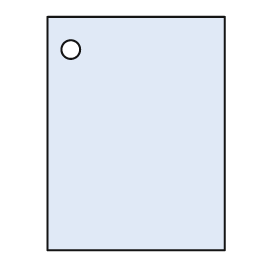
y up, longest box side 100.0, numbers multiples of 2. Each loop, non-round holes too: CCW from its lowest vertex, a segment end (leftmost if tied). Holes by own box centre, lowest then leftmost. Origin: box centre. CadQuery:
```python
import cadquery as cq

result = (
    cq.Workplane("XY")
    .moveTo(-38.0, -50.0)
    .lineTo(38.0, -50.0)
    .lineTo(38.0, 50.0)
    .lineTo(-38.0, 50.0)
    .close()
    .moveTo(-28.0, 36.0)
    .circle(4.0)
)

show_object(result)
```